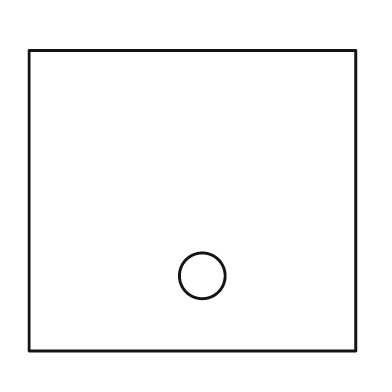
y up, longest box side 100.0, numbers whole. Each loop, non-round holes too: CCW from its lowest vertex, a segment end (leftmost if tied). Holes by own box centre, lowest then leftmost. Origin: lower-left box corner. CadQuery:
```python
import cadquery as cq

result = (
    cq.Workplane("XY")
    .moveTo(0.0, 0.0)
    .lineTo(100.0, 0.0)
    .lineTo(100.0, 92.0)
    .lineTo(0.0, 92.0)
    .close()
    .moveTo(53.0, 23.0)
    .circle(7.0)
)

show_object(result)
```